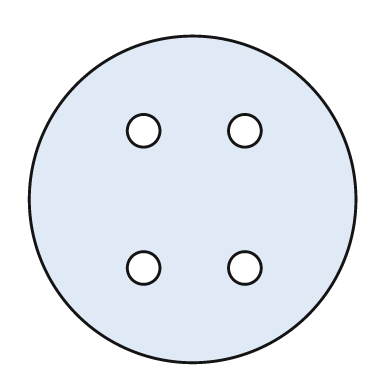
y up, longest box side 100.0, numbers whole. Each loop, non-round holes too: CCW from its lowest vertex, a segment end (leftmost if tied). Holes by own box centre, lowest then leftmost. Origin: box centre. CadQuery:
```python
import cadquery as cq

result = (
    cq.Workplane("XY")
    .moveTo(0.0, 0.0)
    .circle(50.0)
    .moveTo(-15.0, -21.0)
    .circle(5.0)
    .moveTo(16.0, -21.0)
    .circle(5.0)
    .moveTo(-15.0, 21.0)
    .circle(5.0)
    .moveTo(16.0, 21.0)
    .circle(5.0)
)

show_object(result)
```